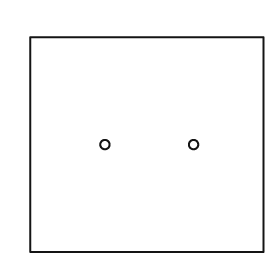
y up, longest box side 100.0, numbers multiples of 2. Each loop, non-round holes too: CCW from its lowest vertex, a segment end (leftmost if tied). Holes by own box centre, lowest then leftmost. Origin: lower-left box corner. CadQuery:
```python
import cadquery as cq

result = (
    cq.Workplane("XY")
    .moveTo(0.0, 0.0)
    .lineTo(100.0, 0.0)
    .lineTo(100.0, 92.0)
    .lineTo(0.0, 92.0)
    .close()
    .moveTo(32.0, 46.0)
    .circle(2.0)
    .moveTo(70.0, 46.0)
    .circle(2.0)
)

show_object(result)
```